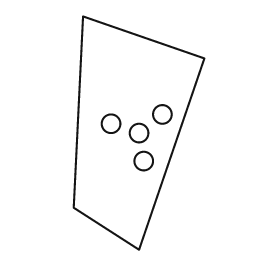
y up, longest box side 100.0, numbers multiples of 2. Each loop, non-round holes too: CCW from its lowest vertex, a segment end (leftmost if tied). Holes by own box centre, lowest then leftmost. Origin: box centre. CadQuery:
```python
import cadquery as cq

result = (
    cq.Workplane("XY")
    .moveTo(0.0, -50.0)
    .lineTo(28.0, 32.0)
    .lineTo(-24.0, 50.0)
    .lineTo(-28.0, -32.0)
    .close()
    .moveTo(2.0, -12.0)
    .circle(4.0)
    .moveTo(0.0, 0.0)
    .circle(4.0)
    .moveTo(-12.0, 4.0)
    .circle(4.0)
    .moveTo(10.0, 8.0)
    .circle(4.0)
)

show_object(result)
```